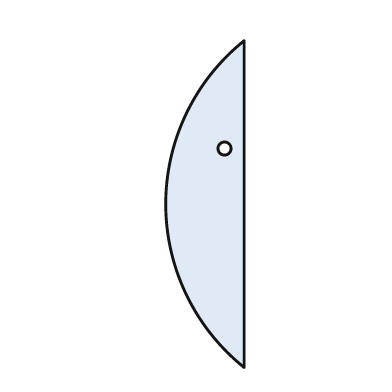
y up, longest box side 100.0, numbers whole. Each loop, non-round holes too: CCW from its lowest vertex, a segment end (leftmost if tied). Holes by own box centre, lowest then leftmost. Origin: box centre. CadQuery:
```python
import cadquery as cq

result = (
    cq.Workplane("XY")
    .moveTo(12.0, -50.0)
    .lineTo(12.0, 50.0)
    .threePointArc((-12.0, 0.0), (12.0, -50.0))
    .close()
    .moveTo(6.0, 17.0)
    .circle(2.0)
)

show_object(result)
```